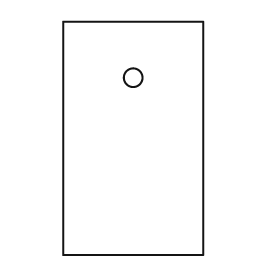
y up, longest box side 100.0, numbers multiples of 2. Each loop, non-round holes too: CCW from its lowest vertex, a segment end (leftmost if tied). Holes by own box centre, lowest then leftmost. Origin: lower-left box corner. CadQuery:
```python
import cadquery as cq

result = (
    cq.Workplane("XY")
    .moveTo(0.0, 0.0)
    .lineTo(60.0, 0.0)
    .lineTo(60.0, 100.0)
    .lineTo(0.0, 100.0)
    .close()
    .moveTo(30.0, 76.0)
    .circle(4.0)
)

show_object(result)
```